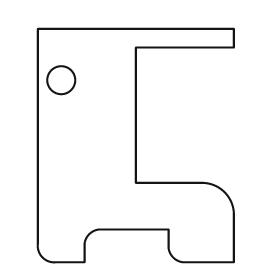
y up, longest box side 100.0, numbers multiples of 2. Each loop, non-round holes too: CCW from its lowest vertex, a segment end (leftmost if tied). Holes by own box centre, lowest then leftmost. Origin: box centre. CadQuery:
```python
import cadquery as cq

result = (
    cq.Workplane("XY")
    .moveTo(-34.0, -50.0)
    .lineTo(-22.0, -50.0)
    .lineTo(-22.0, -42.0)
    .threePointArc((-20.0, -38.0), (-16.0, -36.0))
    .lineTo(14.0, -36.0)
    .lineTo(14.0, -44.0)
    .threePointArc((16.0, -48.0), (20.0, -50.0))
    .lineTo(42.0, -50.0)
    .lineTo(42.0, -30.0)
    .threePointArc((38.0, -20.0), (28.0, -16.0))
    .lineTo(0.0, -16.0)
    .lineTo(0.0, 42.0)
    .lineTo(42.0, 42.0)
    .lineTo(42.0, 50.0)
    .lineTo(-42.0, 50.0)
    .lineTo(-42.0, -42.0)
    .threePointArc((-40.0, -48.0), (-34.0, -50.0))
    .close()
    .moveTo(-32.0, 28.0)
    .circle(6.0)
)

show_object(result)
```